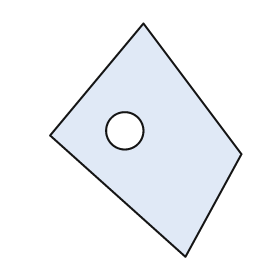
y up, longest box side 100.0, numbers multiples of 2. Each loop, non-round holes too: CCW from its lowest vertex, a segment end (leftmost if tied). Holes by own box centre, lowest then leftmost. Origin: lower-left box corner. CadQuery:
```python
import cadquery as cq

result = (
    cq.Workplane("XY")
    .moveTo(58.0, 0.0)
    .lineTo(82.0, 44.0)
    .lineTo(40.0, 100.0)
    .lineTo(0.0, 52.0)
    .close()
    .moveTo(32.0, 54.0)
    .circle(8.0)
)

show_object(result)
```